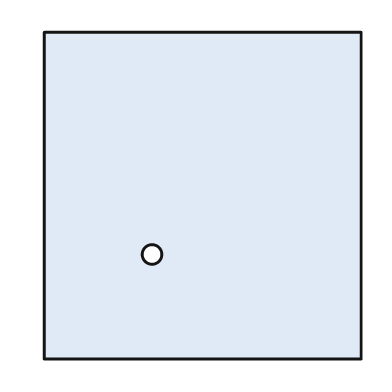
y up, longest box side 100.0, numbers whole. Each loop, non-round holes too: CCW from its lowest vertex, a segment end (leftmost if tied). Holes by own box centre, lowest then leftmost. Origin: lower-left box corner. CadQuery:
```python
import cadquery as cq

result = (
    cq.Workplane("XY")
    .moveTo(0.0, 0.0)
    .lineTo(97.0, 0.0)
    .lineTo(97.0, 100.0)
    .lineTo(0.0, 100.0)
    .close()
    .moveTo(33.0, 32.0)
    .circle(3.0)
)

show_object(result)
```